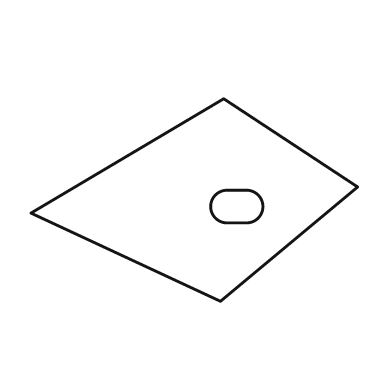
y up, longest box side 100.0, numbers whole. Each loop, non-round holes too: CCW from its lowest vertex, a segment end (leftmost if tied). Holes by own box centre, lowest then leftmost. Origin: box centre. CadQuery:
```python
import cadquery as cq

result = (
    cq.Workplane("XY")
    .moveTo(8.0, -31.0)
    .lineTo(50.0, 4.0)
    .lineTo(9.0, 31.0)
    .lineTo(-50.0, -4.0)
    .close()
    .moveTo(10.0, -7.0)
    .lineTo(16.0, -7.0)
    .threePointArc((21.0, -2.0), (16.0, 3.0))
    .lineTo(10.0, 3.0)
    .threePointArc((5.0, -2.0), (10.0, -7.0))
    .close()
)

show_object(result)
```